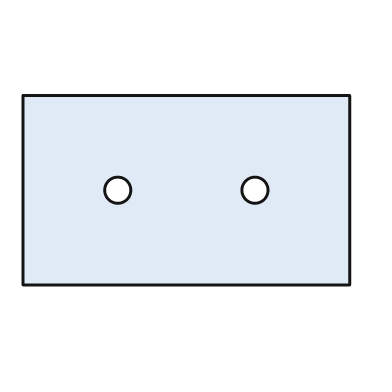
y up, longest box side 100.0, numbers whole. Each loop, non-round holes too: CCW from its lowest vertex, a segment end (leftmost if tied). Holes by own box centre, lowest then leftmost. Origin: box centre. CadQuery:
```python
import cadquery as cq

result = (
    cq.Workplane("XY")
    .moveTo(-50.0, -29.0)
    .lineTo(50.0, -29.0)
    .lineTo(50.0, 29.0)
    .lineTo(-50.0, 29.0)
    .close()
    .moveTo(-21.0, 0.0)
    .circle(4.0)
    .moveTo(21.0, 0.0)
    .circle(4.0)
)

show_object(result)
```